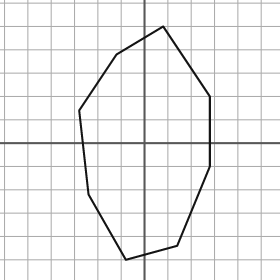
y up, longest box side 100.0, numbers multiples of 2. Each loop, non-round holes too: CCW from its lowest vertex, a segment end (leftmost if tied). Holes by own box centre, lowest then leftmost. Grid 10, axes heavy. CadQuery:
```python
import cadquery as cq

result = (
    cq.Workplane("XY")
    .moveTo(-8.0, -50.0)
    .lineTo(14.0, -44.0)
    .lineTo(28.0, -10.0)
    .lineTo(28.0, 20.0)
    .lineTo(8.0, 50.0)
    .lineTo(-12.0, 38.0)
    .lineTo(-28.0, 14.0)
    .lineTo(-24.0, -22.0)
    .close()
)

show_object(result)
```